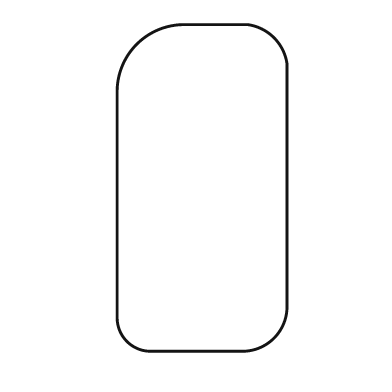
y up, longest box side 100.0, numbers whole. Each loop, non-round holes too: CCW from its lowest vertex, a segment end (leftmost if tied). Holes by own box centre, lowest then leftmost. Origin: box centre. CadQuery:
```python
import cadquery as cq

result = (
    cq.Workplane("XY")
    .moveTo(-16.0, -50.0)
    .lineTo(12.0, -50.0)
    .threePointArc((22.0, -46.0), (26.0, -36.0))
    .lineTo(26.0, 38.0)
    .threePointArc((22.0, 46.0), (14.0, 50.0))
    .lineTo(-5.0, 50.0)
    .threePointArc((-20.0, 44.0), (-26.0, 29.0))
    .lineTo(-26.0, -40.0)
    .threePointArc((-23.0, -47.0), (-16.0, -50.0))
    .close()
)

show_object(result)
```